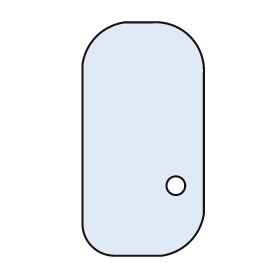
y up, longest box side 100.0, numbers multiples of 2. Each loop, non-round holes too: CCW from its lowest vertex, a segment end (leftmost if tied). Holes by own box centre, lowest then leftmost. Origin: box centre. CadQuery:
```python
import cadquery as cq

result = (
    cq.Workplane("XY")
    .moveTo(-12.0, -50.0)
    .lineTo(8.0, -50.0)
    .threePointArc((20.0, -44.0), (26.0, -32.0))
    .lineTo(26.0, 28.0)
    .threePointArc((20.0, 44.0), (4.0, 50.0))
    .lineTo(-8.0, 50.0)
    .threePointArc((-20.0, 44.0), (-26.0, 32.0))
    .lineTo(-26.0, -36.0)
    .threePointArc((-22.0, -46.0), (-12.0, -50.0))
    .close()
    .moveTo(14.0, -20.0)
    .circle(4.0)
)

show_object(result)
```